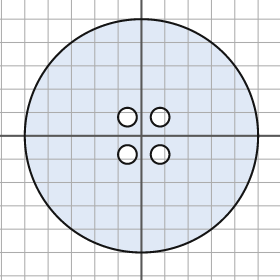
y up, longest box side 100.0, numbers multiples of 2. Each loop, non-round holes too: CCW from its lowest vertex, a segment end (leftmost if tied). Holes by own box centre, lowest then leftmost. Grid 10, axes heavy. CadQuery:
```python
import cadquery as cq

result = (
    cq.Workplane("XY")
    .moveTo(0.0, 0.0)
    .circle(50.0)
    .moveTo(-6.0, -8.0)
    .circle(4.0)
    .moveTo(8.0, -8.0)
    .circle(4.0)
    .moveTo(-6.0, 8.0)
    .circle(4.0)
    .moveTo(8.0, 8.0)
    .circle(4.0)
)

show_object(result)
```